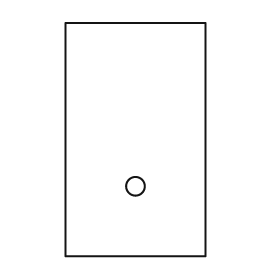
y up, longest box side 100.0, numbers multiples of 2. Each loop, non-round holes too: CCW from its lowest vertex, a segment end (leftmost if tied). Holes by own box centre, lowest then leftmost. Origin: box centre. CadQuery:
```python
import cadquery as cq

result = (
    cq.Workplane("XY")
    .moveTo(-30.0, -50.0)
    .lineTo(30.0, -50.0)
    .lineTo(30.0, 50.0)
    .lineTo(-30.0, 50.0)
    .close()
    .moveTo(0.0, -20.0)
    .circle(4.0)
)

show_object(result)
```